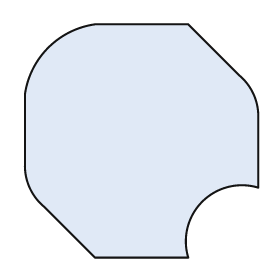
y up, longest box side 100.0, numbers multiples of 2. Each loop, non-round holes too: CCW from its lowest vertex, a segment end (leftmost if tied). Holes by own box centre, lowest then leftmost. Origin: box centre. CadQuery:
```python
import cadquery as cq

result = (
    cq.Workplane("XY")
    .moveTo(-20.0, -50.0)
    .lineTo(20.0, -50.0)
    .threePointArc((26.0, -26.0), (50.0, -20.0))
    .lineTo(50.0, 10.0)
    .threePointArc((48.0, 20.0), (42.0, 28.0))
    .lineTo(20.0, 50.0)
    .lineTo(-20.0, 50.0)
    .threePointArc((-40.0, 40.0), (-50.0, 20.0))
    .lineTo(-50.0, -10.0)
    .threePointArc((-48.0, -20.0), (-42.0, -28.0))
    .close()
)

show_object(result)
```